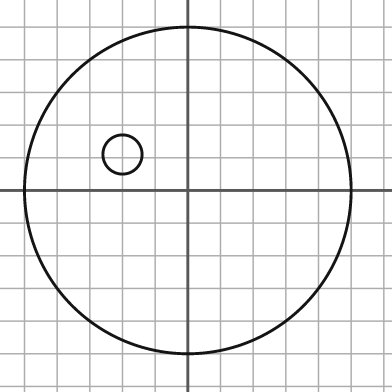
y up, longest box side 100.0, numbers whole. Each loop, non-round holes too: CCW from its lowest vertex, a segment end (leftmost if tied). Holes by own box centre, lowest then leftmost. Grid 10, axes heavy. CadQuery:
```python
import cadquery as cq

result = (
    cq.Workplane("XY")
    .moveTo(0.0, 0.0)
    .circle(50.0)
    .moveTo(-20.0, 11.0)
    .circle(6.0)
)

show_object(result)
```